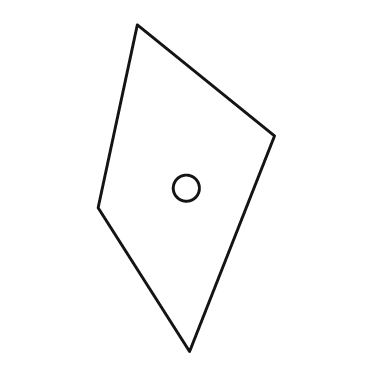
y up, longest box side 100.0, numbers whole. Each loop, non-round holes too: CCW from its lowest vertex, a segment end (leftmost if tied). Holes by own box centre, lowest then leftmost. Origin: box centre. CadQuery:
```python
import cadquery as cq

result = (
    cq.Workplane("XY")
    .moveTo(1.0, -50.0)
    .lineTo(27.0, 16.0)
    .lineTo(-15.0, 50.0)
    .lineTo(-27.0, -6.0)
    .close()
    .moveTo(0.0, 0.0)
    .circle(4.0)
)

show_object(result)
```